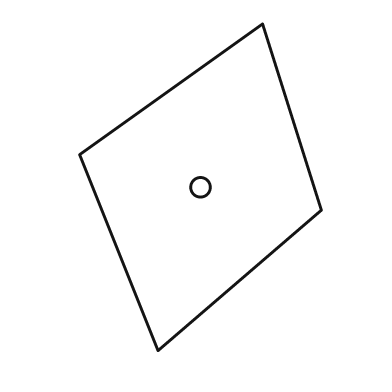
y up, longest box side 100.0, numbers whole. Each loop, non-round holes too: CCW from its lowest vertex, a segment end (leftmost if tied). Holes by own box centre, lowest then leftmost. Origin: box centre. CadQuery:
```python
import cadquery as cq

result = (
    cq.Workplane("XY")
    .moveTo(-13.0, -50.0)
    .lineTo(37.0, -7.0)
    .lineTo(19.0, 50.0)
    .lineTo(-37.0, 10.0)
    .close()
    .moveTo(0.0, 0.0)
    .circle(3.0)
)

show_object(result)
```